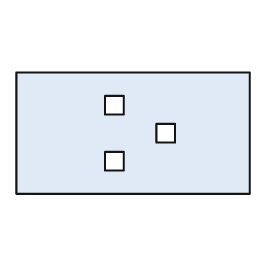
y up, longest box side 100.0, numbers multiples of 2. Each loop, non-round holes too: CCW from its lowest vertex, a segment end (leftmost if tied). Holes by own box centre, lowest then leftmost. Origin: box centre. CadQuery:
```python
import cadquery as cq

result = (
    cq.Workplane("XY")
    .moveTo(-50.0, -26.0)
    .lineTo(50.0, -26.0)
    .lineTo(50.0, 26.0)
    .lineTo(-50.0, 26.0)
    .close()
    .moveTo(-12.0, -16.0)
    .lineTo(-4.0, -16.0)
    .lineTo(-4.0, -8.0)
    .lineTo(-12.0, -8.0)
    .close()
    .moveTo(10.0, -4.0)
    .lineTo(18.0, -4.0)
    .lineTo(18.0, 4.0)
    .lineTo(10.0, 4.0)
    .close()
    .moveTo(-12.0, 8.0)
    .lineTo(-4.0, 8.0)
    .lineTo(-4.0, 16.0)
    .lineTo(-12.0, 16.0)
    .close()
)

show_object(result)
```